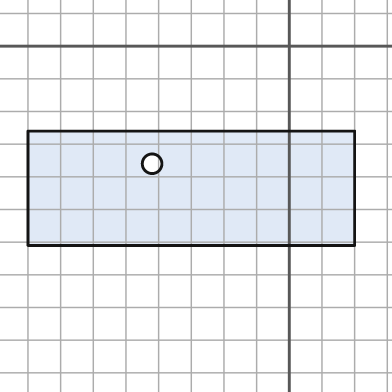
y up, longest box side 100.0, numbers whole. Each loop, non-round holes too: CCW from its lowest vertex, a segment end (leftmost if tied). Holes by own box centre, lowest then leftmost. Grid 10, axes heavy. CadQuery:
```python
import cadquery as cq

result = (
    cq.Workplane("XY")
    .moveTo(-80.0, -61.0)
    .lineTo(20.0, -61.0)
    .lineTo(20.0, -26.0)
    .lineTo(-80.0, -26.0)
    .close()
    .moveTo(-42.0, -36.0)
    .circle(3.0)
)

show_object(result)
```